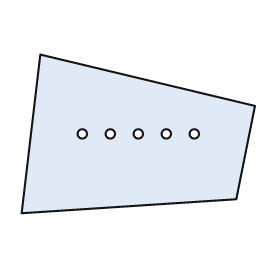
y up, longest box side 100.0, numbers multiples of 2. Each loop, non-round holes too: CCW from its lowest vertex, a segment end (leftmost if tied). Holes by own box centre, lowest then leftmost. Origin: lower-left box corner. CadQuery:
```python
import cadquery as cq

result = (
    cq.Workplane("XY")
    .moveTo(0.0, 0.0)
    .lineTo(92.0, 6.0)
    .lineTo(100.0, 46.0)
    .lineTo(8.0, 68.0)
    .close()
    .moveTo(26.0, 34.0)
    .circle(2.0)
    .moveTo(38.0, 34.0)
    .circle(2.0)
    .moveTo(50.0, 34.0)
    .circle(2.0)
    .moveTo(62.0, 34.0)
    .circle(2.0)
    .moveTo(74.0, 34.0)
    .circle(2.0)
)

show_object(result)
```